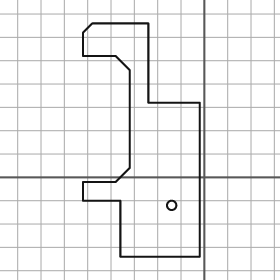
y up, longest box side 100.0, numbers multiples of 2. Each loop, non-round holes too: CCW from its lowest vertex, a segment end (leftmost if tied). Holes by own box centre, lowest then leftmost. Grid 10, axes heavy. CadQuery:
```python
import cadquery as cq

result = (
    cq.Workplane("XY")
    .moveTo(-36.0, -34.0)
    .lineTo(-2.0, -34.0)
    .lineTo(-2.0, 32.0)
    .lineTo(-24.0, 32.0)
    .lineTo(-24.0, 66.0)
    .lineTo(-48.0, 66.0)
    .lineTo(-52.0, 62.0)
    .lineTo(-52.0, 52.0)
    .lineTo(-38.0, 52.0)
    .lineTo(-32.0, 46.0)
    .lineTo(-32.0, 4.0)
    .lineTo(-38.0, -2.0)
    .lineTo(-52.0, -2.0)
    .lineTo(-52.0, -10.0)
    .lineTo(-36.0, -10.0)
    .close()
    .moveTo(-14.0, -12.0)
    .circle(2.0)
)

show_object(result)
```